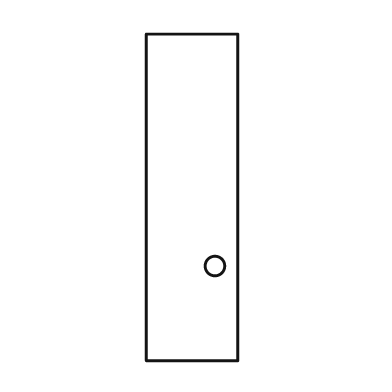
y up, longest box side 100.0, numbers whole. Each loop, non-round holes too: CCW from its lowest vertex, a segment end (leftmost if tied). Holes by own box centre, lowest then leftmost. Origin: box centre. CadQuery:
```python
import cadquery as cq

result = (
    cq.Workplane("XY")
    .moveTo(-14.0, -50.0)
    .lineTo(14.0, -50.0)
    .lineTo(14.0, 50.0)
    .lineTo(-14.0, 50.0)
    .close()
    .moveTo(7.0, -21.0)
    .circle(3.0)
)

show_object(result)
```